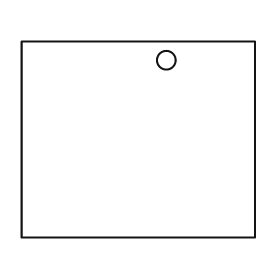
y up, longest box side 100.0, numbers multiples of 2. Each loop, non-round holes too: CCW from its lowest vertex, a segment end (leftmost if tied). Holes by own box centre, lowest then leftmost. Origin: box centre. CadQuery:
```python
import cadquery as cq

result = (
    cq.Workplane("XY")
    .moveTo(-50.0, -42.0)
    .lineTo(50.0, -42.0)
    .lineTo(50.0, 42.0)
    .lineTo(-50.0, 42.0)
    .close()
    .moveTo(12.0, 34.0)
    .circle(4.0)
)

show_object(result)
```